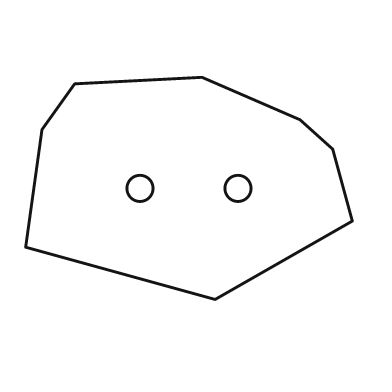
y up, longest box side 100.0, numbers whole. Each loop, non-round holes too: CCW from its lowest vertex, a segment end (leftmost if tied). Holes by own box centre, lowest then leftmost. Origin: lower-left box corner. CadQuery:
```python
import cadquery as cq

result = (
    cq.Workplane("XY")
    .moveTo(58.0, 0.0)
    .lineTo(100.0, 24.0)
    .lineTo(94.0, 46.0)
    .lineTo(84.0, 55.0)
    .lineTo(54.0, 68.0)
    .lineTo(15.0, 66.0)
    .lineTo(5.0, 52.0)
    .lineTo(0.0, 16.0)
    .close()
    .moveTo(35.0, 34.0)
    .circle(4.0)
    .moveTo(65.0, 34.0)
    .circle(4.0)
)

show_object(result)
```